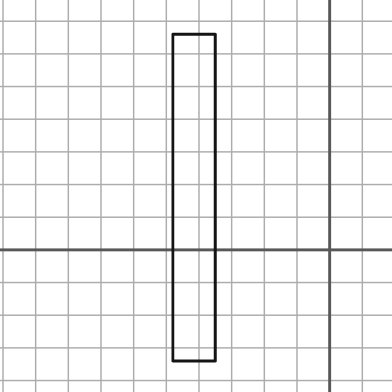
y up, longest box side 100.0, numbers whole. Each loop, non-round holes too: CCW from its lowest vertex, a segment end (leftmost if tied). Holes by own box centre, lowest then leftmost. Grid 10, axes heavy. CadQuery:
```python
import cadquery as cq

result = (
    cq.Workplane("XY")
    .moveTo(-48.0, -34.0)
    .lineTo(-35.0, -34.0)
    .lineTo(-35.0, 66.0)
    .lineTo(-48.0, 66.0)
    .close()
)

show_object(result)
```